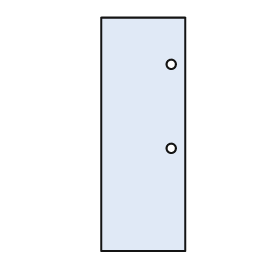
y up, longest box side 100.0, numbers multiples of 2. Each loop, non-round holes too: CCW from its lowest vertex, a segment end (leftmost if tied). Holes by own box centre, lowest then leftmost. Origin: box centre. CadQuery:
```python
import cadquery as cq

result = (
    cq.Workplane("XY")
    .moveTo(-18.0, -50.0)
    .lineTo(18.0, -50.0)
    .lineTo(18.0, 50.0)
    .lineTo(-18.0, 50.0)
    .close()
    .moveTo(12.0, -6.0)
    .circle(2.0)
    .moveTo(12.0, 30.0)
    .circle(2.0)
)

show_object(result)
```